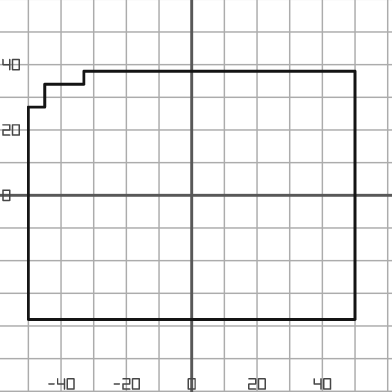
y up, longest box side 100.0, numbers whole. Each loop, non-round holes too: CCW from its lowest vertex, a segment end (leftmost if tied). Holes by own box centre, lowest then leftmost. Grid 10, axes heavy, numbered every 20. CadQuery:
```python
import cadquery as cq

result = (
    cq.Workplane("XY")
    .moveTo(-50.0, -38.0)
    .lineTo(50.0, -38.0)
    .lineTo(50.0, 38.0)
    .lineTo(-33.0, 38.0)
    .lineTo(-33.0, 34.0)
    .lineTo(-45.0, 34.0)
    .lineTo(-45.0, 27.0)
    .lineTo(-50.0, 27.0)
    .close()
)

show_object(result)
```